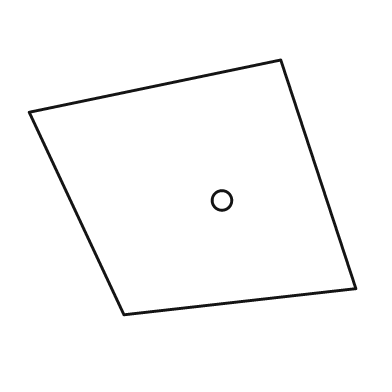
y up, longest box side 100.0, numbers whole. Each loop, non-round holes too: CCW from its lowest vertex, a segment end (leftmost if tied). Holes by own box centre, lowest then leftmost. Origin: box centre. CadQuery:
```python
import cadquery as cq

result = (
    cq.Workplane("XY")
    .moveTo(-21.0, -39.0)
    .lineTo(50.0, -31.0)
    .lineTo(27.0, 39.0)
    .lineTo(-50.0, 23.0)
    .close()
    .moveTo(9.0, -4.0)
    .circle(3.0)
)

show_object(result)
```